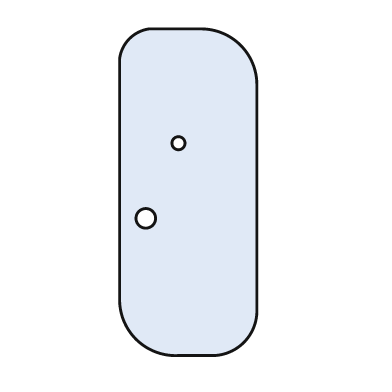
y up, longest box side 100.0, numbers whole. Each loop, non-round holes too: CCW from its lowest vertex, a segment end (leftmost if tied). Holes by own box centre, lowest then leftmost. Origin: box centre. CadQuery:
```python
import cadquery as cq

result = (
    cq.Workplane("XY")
    .moveTo(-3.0, -50.0)
    .lineTo(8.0, -50.0)
    .threePointArc((17.0, -46.0), (21.0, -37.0))
    .lineTo(21.0, 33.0)
    .threePointArc((16.0, 45.0), (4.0, 50.0))
    .lineTo(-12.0, 50.0)
    .threePointArc((-18.0, 47.0), (-21.0, 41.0))
    .lineTo(-21.0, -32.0)
    .threePointArc((-16.0, -45.0), (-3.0, -50.0))
    .close()
    .moveTo(-13.0, -8.0)
    .circle(3.0)
    .moveTo(-3.0, 15.0)
    .circle(2.0)
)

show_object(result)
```